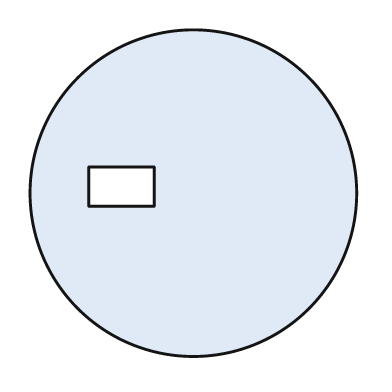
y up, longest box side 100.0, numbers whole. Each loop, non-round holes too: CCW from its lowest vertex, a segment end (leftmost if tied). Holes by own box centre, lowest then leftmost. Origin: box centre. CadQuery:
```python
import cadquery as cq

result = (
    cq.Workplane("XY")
    .moveTo(0.0, 0.0)
    .circle(50.0)
    .moveTo(-32.0, -4.0)
    .lineTo(-12.0, -4.0)
    .lineTo(-12.0, 8.0)
    .lineTo(-32.0, 8.0)
    .close()
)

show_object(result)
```